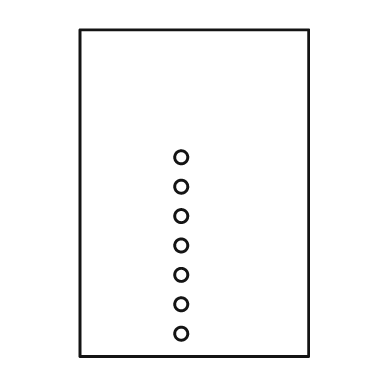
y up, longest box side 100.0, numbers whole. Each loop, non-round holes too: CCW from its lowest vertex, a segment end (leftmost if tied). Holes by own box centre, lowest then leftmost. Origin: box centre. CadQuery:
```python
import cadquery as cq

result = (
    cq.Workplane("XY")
    .moveTo(-35.0, -50.0)
    .lineTo(35.0, -50.0)
    .lineTo(35.0, 50.0)
    .lineTo(-35.0, 50.0)
    .close()
    .moveTo(-4.0, -43.0)
    .circle(2.0)
    .moveTo(-4.0, -34.0)
    .circle(2.0)
    .moveTo(-4.0, -25.0)
    .circle(2.0)
    .moveTo(-4.0, -16.0)
    .circle(2.0)
    .moveTo(-4.0, -7.0)
    .circle(2.0)
    .moveTo(-4.0, 2.0)
    .circle(2.0)
    .moveTo(-4.0, 11.0)
    .circle(2.0)
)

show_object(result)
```